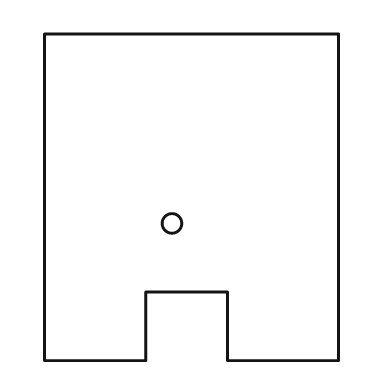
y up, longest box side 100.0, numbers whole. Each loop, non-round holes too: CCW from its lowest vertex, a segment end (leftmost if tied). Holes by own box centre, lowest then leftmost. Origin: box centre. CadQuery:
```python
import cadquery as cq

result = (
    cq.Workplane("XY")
    .moveTo(-45.0, -50.0)
    .lineTo(-14.0, -50.0)
    .lineTo(-14.0, -29.0)
    .lineTo(11.0, -29.0)
    .lineTo(11.0, -50.0)
    .lineTo(45.0, -50.0)
    .lineTo(45.0, 50.0)
    .lineTo(-45.0, 50.0)
    .close()
    .moveTo(-6.0, -8.0)
    .circle(3.0)
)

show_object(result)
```